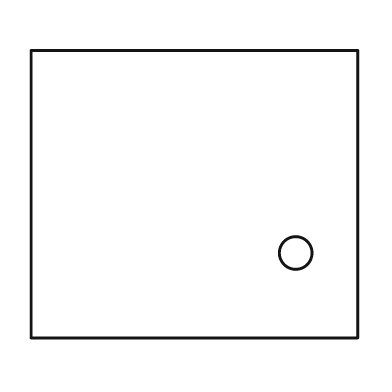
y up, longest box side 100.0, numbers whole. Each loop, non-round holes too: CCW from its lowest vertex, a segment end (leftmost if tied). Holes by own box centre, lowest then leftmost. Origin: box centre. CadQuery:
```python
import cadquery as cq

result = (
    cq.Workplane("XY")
    .moveTo(-50.0, -44.0)
    .lineTo(50.0, -44.0)
    .lineTo(50.0, 44.0)
    .lineTo(-50.0, 44.0)
    .close()
    .moveTo(31.0, -18.0)
    .circle(5.0)
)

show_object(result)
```